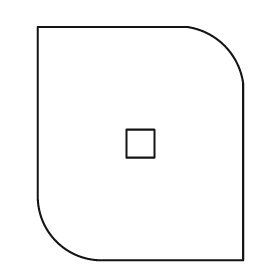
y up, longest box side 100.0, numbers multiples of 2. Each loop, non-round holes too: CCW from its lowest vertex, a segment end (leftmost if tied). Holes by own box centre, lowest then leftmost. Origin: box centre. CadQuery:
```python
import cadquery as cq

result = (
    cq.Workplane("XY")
    .moveTo(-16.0, -50.0)
    .lineTo(44.0, -50.0)
    .lineTo(44.0, 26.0)
    .threePointArc((36.0, 42.0), (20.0, 50.0))
    .lineTo(-44.0, 50.0)
    .lineTo(-44.0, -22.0)
    .threePointArc((-36.0, -42.0), (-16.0, -50.0))
    .close()
    .moveTo(-6.0, -6.0)
    .lineTo(6.0, -6.0)
    .lineTo(6.0, 6.0)
    .lineTo(-6.0, 6.0)
    .close()
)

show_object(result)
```